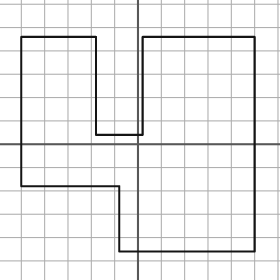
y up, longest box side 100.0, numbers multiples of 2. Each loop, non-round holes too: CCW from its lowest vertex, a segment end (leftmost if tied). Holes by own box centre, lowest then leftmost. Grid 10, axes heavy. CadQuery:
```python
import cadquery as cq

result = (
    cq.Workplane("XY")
    .moveTo(-8.0, -46.0)
    .lineTo(50.0, -46.0)
    .lineTo(50.0, 46.0)
    .lineTo(2.0, 46.0)
    .lineTo(2.0, 4.0)
    .lineTo(-18.0, 4.0)
    .lineTo(-18.0, 46.0)
    .lineTo(-50.0, 46.0)
    .lineTo(-50.0, -18.0)
    .lineTo(-8.0, -18.0)
    .close()
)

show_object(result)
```